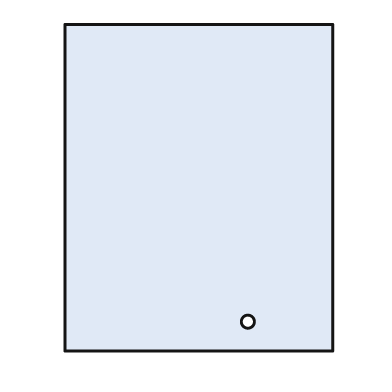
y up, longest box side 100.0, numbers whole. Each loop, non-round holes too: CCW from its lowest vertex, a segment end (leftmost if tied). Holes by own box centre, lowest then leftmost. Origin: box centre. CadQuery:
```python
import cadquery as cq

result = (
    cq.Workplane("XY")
    .moveTo(-41.0, -50.0)
    .lineTo(41.0, -50.0)
    .lineTo(41.0, 50.0)
    .lineTo(-41.0, 50.0)
    .close()
    .moveTo(15.0, -41.0)
    .circle(2.0)
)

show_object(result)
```